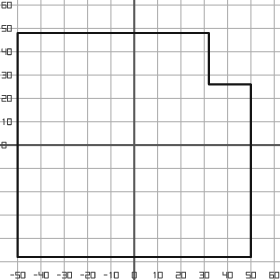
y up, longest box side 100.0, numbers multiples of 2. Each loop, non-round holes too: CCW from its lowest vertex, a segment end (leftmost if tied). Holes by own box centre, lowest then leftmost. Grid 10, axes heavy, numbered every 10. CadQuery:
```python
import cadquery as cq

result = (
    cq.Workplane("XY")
    .moveTo(-50.0, -48.0)
    .lineTo(50.0, -48.0)
    .lineTo(50.0, 26.0)
    .lineTo(32.0, 26.0)
    .lineTo(32.0, 48.0)
    .lineTo(-50.0, 48.0)
    .close()
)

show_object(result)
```